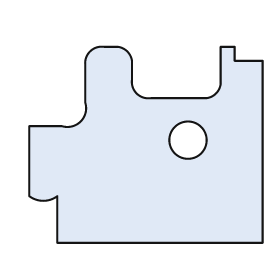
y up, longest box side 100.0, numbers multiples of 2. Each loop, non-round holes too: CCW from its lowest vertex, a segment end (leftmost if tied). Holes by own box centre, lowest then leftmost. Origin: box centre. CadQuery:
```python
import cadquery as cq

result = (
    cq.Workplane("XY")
    .moveTo(-38.0, -42.0)
    .lineTo(50.0, -42.0)
    .lineTo(50.0, 36.0)
    .lineTo(38.0, 36.0)
    .lineTo(38.0, 42.0)
    .lineTo(32.0, 42.0)
    .lineTo(32.0, 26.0)
    .threePointArc((30.0, 22.0), (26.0, 20.0))
    .lineTo(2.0, 20.0)
    .threePointArc((-4.0, 22.0), (-6.0, 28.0))
    .lineTo(-6.0, 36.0)
    .threePointArc((-8.0, 40.0), (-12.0, 42.0))
    .lineTo(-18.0, 42.0)
    .threePointArc((-24.0, 40.0), (-26.0, 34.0))
    .lineTo(-26.0, 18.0)
    .threePointArc((-28.0, 10.0), (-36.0, 8.0))
    .lineTo(-50.0, 8.0)
    .lineTo(-50.0, -22.0)
    .threePointArc((-44.0, -24.0), (-38.0, -22.0))
    .close()
    .moveTo(18.0, 2.0)
    .circle(8.0)
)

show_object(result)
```